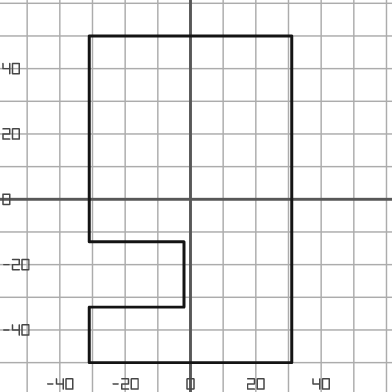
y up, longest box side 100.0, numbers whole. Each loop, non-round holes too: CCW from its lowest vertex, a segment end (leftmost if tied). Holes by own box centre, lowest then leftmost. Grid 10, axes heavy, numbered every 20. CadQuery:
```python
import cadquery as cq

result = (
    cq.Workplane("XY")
    .moveTo(-31.0, -50.0)
    .lineTo(31.0, -50.0)
    .lineTo(31.0, 50.0)
    .lineTo(-31.0, 50.0)
    .lineTo(-31.0, -13.0)
    .lineTo(-2.0, -13.0)
    .lineTo(-2.0, -33.0)
    .lineTo(-31.0, -33.0)
    .close()
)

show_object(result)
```